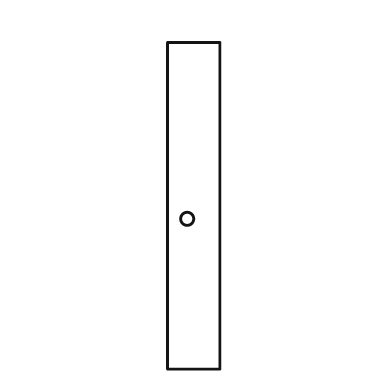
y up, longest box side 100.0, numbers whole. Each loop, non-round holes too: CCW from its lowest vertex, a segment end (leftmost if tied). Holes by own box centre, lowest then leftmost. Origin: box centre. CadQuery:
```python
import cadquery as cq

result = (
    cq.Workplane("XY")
    .moveTo(-8.0, -50.0)
    .lineTo(8.0, -50.0)
    .lineTo(8.0, 50.0)
    .lineTo(-8.0, 50.0)
    .close()
    .moveTo(-2.0, -4.0)
    .circle(2.0)
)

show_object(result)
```